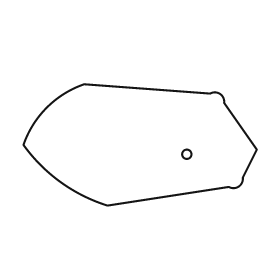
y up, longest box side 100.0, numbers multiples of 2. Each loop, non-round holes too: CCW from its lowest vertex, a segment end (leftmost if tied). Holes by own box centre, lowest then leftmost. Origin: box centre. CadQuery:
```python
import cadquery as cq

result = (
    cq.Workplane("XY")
    .moveTo(-14.0, -26.0)
    .lineTo(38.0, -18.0)
    .threePointArc((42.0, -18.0), (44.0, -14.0))
    .lineTo(50.0, -2.0)
    .lineTo(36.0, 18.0)
    .threePointArc((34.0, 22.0), (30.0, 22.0))
    .lineTo(-24.0, 26.0)
    .threePointArc((-40.0, 16.0), (-50.0, 0.0))
    .threePointArc((-34.0, -16.0), (-14.0, -26.0))
    .close()
    .moveTo(20.0, -4.0)
    .circle(2.0)
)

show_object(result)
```